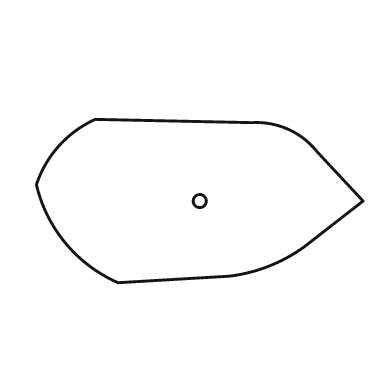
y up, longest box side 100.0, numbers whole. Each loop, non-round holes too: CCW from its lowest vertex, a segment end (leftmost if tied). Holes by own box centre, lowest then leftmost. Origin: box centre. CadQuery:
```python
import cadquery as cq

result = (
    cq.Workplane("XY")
    .moveTo(-25.0, -25.0)
    .lineTo(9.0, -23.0)
    .threePointArc((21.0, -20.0), (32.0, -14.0))
    .lineTo(50.0, 0.0)
    .lineTo(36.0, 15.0)
    .threePointArc((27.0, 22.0), (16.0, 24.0))
    .lineTo(-32.0, 25.0)
    .threePointArc((-43.0, 17.0), (-50.0, 5.0))
    .threePointArc((-41.0, -13.0), (-25.0, -25.0))
    .close()
    .moveTo(0.0, 0.0)
    .circle(2.0)
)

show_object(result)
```